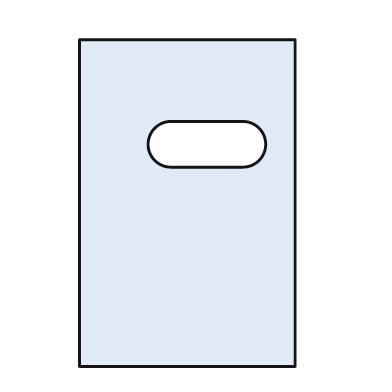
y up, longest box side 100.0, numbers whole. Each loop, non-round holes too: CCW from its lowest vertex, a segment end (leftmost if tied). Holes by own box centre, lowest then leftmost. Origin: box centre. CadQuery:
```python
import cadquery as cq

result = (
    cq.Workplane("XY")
    .moveTo(-33.0, -50.0)
    .lineTo(33.0, -50.0)
    .lineTo(33.0, 50.0)
    .lineTo(-33.0, 50.0)
    .close()
    .moveTo(-5.0, 11.0)
    .lineTo(17.0, 11.0)
    .threePointArc((24.0, 18.0), (17.0, 25.0))
    .lineTo(-5.0, 25.0)
    .threePointArc((-12.0, 18.0), (-5.0, 11.0))
    .close()
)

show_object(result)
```